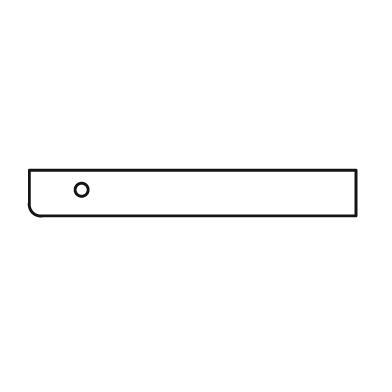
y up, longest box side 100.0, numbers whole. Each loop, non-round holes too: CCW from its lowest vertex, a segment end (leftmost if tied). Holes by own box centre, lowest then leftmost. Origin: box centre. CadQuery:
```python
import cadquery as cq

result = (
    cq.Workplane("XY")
    .moveTo(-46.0, -7.0)
    .lineTo(50.0, -7.0)
    .lineTo(50.0, 7.0)
    .lineTo(-50.0, 7.0)
    .lineTo(-50.0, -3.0)
    .threePointArc((-49.0, -6.0), (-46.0, -7.0))
    .close()
    .moveTo(-34.0, 1.0)
    .circle(2.0)
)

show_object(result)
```